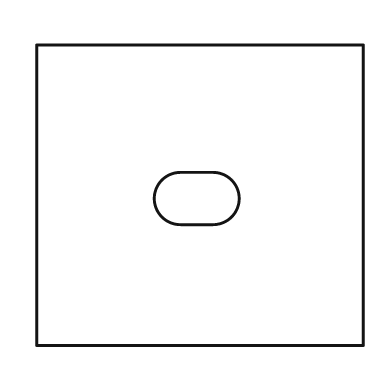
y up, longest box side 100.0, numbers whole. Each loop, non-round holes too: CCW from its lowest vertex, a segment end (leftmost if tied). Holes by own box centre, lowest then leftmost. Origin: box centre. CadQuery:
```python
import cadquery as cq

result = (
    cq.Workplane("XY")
    .moveTo(-50.0, -46.0)
    .lineTo(50.0, -46.0)
    .lineTo(50.0, 46.0)
    .lineTo(-50.0, 46.0)
    .close()
    .moveTo(-6.0, -9.0)
    .lineTo(4.0, -9.0)
    .threePointArc((12.0, -1.0), (4.0, 7.0))
    .lineTo(-6.0, 7.0)
    .threePointArc((-14.0, -1.0), (-6.0, -9.0))
    .close()
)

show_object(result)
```